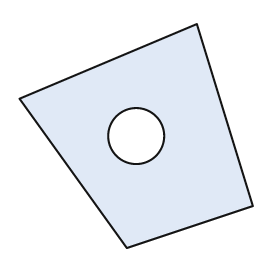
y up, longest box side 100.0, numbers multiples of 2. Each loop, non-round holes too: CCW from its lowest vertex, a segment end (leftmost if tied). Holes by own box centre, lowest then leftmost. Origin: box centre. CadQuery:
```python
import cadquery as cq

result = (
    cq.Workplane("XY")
    .moveTo(-4.0, -48.0)
    .lineTo(50.0, -30.0)
    .lineTo(26.0, 48.0)
    .lineTo(-50.0, 16.0)
    .close()
    .moveTo(0.0, 0.0)
    .circle(12.0)
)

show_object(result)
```